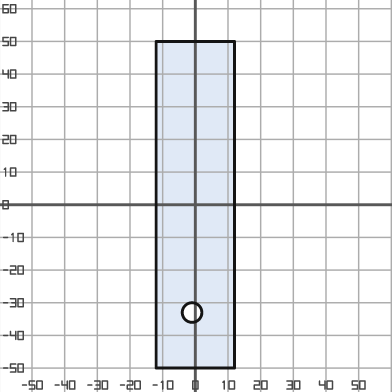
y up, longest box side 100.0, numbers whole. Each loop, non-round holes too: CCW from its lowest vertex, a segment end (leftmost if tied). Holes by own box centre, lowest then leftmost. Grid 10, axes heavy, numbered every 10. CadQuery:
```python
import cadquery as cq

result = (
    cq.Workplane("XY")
    .moveTo(-12.0, -50.0)
    .lineTo(12.0, -50.0)
    .lineTo(12.0, 50.0)
    .lineTo(-12.0, 50.0)
    .close()
    .moveTo(-1.0, -33.0)
    .circle(3.0)
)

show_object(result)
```